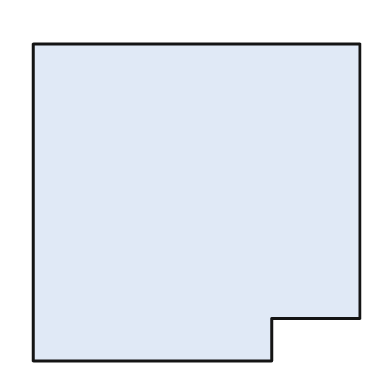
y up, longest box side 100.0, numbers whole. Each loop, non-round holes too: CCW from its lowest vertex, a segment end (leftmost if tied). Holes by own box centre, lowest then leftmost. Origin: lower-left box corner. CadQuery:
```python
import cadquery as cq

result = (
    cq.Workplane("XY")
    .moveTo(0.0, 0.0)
    .lineTo(73.0, 0.0)
    .lineTo(73.0, 13.0)
    .lineTo(100.0, 13.0)
    .lineTo(100.0, 97.0)
    .lineTo(0.0, 97.0)
    .close()
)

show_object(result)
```